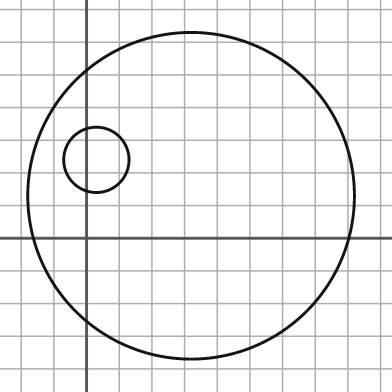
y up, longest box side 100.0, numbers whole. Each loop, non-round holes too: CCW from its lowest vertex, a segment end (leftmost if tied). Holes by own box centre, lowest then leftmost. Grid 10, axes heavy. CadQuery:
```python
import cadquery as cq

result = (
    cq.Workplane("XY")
    .moveTo(32.0, 13.0)
    .circle(50.0)
    .moveTo(3.0, 24.0)
    .circle(10.0)
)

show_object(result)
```